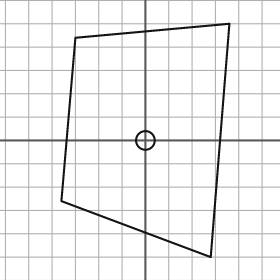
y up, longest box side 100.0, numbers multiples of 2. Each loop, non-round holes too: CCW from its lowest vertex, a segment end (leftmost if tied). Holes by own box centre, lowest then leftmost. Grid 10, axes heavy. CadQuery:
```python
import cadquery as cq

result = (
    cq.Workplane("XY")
    .moveTo(28.0, -50.0)
    .lineTo(36.0, 50.0)
    .lineTo(-30.0, 44.0)
    .lineTo(-36.0, -26.0)
    .close()
    .moveTo(0.0, 0.0)
    .circle(4.0)
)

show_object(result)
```